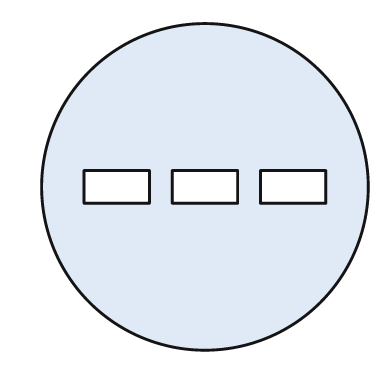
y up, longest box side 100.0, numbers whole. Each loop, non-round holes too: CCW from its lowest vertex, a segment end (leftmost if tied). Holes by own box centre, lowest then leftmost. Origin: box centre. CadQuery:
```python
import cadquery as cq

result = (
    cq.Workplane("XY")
    .moveTo(0.0, 0.0)
    .circle(50.0)
    .moveTo(-37.0, -5.0)
    .lineTo(-17.0, -5.0)
    .lineTo(-17.0, 5.0)
    .lineTo(-37.0, 5.0)
    .close()
    .moveTo(-10.0, -5.0)
    .lineTo(10.0, -5.0)
    .lineTo(10.0, 5.0)
    .lineTo(-10.0, 5.0)
    .close()
    .moveTo(17.0, -5.0)
    .lineTo(37.0, -5.0)
    .lineTo(37.0, 5.0)
    .lineTo(17.0, 5.0)
    .close()
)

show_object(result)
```